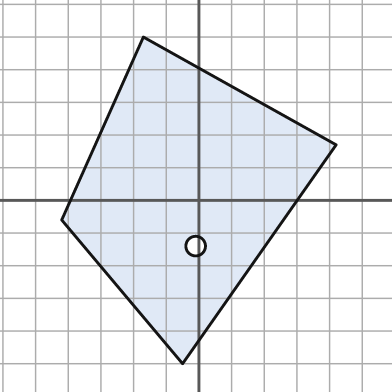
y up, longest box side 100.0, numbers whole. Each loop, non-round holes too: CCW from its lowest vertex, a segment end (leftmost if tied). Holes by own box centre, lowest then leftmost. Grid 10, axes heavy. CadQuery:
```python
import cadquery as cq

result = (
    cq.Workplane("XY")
    .moveTo(-5.0, -50.0)
    .lineTo(42.0, 17.0)
    .lineTo(-17.0, 50.0)
    .lineTo(-42.0, -6.0)
    .close()
    .moveTo(-1.0, -14.0)
    .circle(3.0)
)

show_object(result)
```